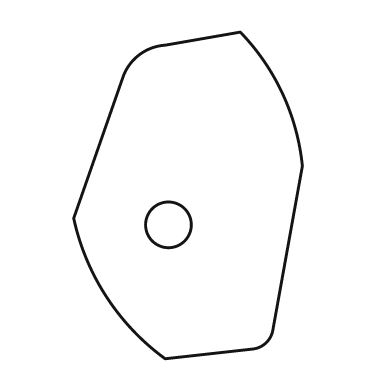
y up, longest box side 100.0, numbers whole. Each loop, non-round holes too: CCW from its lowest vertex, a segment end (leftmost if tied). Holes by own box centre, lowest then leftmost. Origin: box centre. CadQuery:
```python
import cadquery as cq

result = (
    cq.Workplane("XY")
    .moveTo(-7.0, -50.0)
    .lineTo(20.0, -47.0)
    .threePointArc((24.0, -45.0), (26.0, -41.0))
    .lineTo(35.0, 9.0)
    .threePointArc((29.0, 31.0), (16.0, 50.0))
    .lineTo(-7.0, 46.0)
    .threePointArc((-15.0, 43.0), (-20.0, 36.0))
    .lineTo(-35.0, -7.0)
    .threePointArc((-25.0, -31.0), (-7.0, -50.0))
    .close()
    .moveTo(-6.0, -9.0)
    .circle(7.0)
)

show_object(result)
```